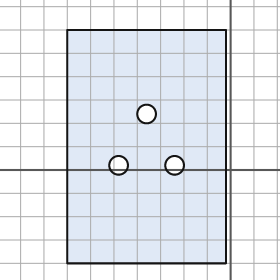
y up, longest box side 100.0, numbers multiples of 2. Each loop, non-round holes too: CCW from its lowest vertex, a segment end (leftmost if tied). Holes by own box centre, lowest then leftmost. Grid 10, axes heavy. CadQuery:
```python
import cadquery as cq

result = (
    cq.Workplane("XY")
    .moveTo(-70.0, -40.0)
    .lineTo(-2.0, -40.0)
    .lineTo(-2.0, 60.0)
    .lineTo(-70.0, 60.0)
    .close()
    .moveTo(-48.0, 2.0)
    .circle(4.0)
    .moveTo(-24.0, 2.0)
    .circle(4.0)
    .moveTo(-36.0, 24.0)
    .circle(4.0)
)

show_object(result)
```